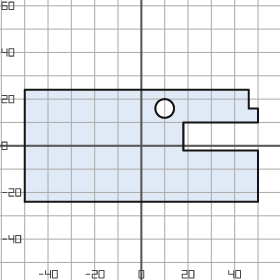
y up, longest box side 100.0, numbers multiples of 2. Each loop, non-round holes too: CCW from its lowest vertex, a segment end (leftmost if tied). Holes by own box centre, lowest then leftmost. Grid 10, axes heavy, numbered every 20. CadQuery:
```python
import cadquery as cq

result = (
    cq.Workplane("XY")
    .moveTo(-50.0, -24.0)
    .lineTo(50.0, -24.0)
    .lineTo(50.0, -2.0)
    .lineTo(18.0, -2.0)
    .lineTo(18.0, 10.0)
    .lineTo(50.0, 10.0)
    .lineTo(50.0, 16.0)
    .lineTo(46.0, 16.0)
    .lineTo(46.0, 24.0)
    .lineTo(-50.0, 24.0)
    .close()
    .moveTo(10.0, 16.0)
    .circle(4.0)
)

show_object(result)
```